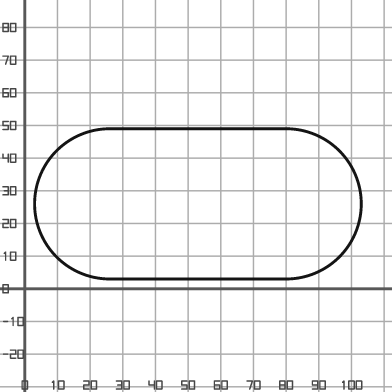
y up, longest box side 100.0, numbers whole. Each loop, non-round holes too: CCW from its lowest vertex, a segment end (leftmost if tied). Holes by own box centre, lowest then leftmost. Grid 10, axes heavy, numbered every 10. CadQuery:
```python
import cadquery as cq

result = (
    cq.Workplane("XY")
    .moveTo(26.0, 3.0)
    .lineTo(80.0, 3.0)
    .threePointArc((103.0, 26.0), (80.0, 49.0))
    .lineTo(26.0, 49.0)
    .threePointArc((3.0, 26.0), (26.0, 3.0))
    .close()
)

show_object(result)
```